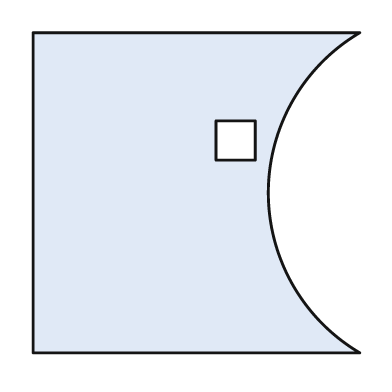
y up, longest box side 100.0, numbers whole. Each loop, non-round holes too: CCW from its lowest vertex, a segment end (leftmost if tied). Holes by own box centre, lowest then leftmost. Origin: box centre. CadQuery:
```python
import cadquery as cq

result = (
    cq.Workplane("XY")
    .moveTo(-50.0, -49.0)
    .lineTo(50.0, -49.0)
    .threePointArc((22.0, 0.0), (50.0, 49.0))
    .lineTo(-50.0, 49.0)
    .close()
    .moveTo(6.0, 10.0)
    .lineTo(18.0, 10.0)
    .lineTo(18.0, 22.0)
    .lineTo(6.0, 22.0)
    .close()
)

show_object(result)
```